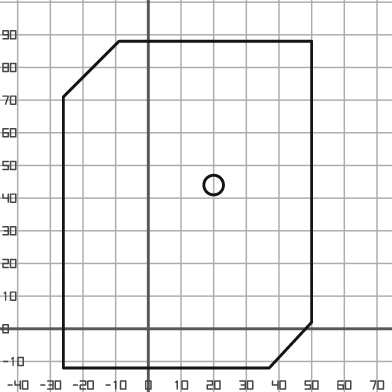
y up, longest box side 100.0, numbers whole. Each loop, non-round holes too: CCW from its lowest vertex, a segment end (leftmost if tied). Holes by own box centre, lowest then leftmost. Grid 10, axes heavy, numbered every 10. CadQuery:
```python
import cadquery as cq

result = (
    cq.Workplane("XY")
    .moveTo(-26.0, -12.0)
    .lineTo(37.0, -12.0)
    .lineTo(50.0, 2.0)
    .lineTo(50.0, 88.0)
    .lineTo(-9.0, 88.0)
    .lineTo(-26.0, 71.0)
    .close()
    .moveTo(20.0, 44.0)
    .circle(3.0)
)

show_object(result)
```